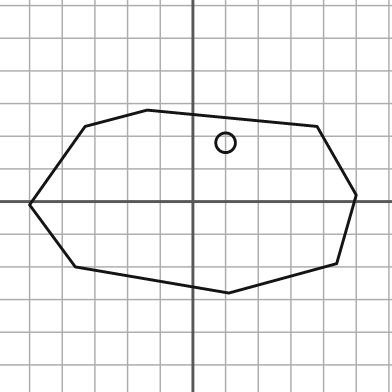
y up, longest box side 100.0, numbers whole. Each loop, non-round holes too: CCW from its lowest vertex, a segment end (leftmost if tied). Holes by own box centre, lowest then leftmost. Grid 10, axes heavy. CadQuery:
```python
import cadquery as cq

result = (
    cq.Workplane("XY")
    .moveTo(11.0, -28.0)
    .lineTo(44.0, -19.0)
    .lineTo(50.0, 2.0)
    .lineTo(38.0, 23.0)
    .lineTo(-14.0, 28.0)
    .lineTo(-33.0, 23.0)
    .lineTo(-50.0, -1.0)
    .lineTo(-36.0, -20.0)
    .close()
    .moveTo(10.0, 18.0)
    .circle(3.0)
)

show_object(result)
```